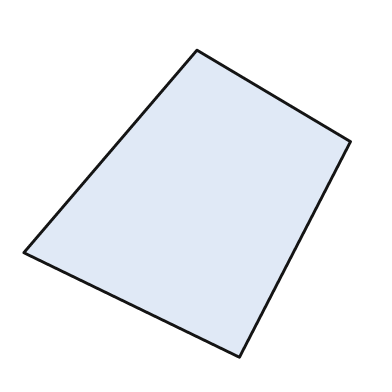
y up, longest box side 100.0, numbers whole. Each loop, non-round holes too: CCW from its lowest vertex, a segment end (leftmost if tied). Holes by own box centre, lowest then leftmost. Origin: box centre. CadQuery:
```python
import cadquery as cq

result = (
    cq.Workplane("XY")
    .moveTo(16.0, -47.0)
    .lineTo(50.0, 19.0)
    .lineTo(3.0, 47.0)
    .lineTo(-50.0, -15.0)
    .close()
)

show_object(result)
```